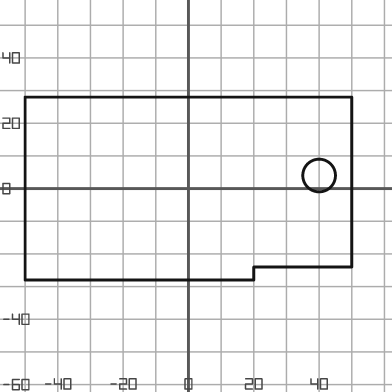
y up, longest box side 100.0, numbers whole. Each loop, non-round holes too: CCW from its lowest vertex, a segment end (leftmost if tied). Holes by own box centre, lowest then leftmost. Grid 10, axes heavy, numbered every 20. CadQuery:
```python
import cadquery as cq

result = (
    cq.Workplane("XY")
    .moveTo(-50.0, -28.0)
    .lineTo(20.0, -28.0)
    .lineTo(20.0, -24.0)
    .lineTo(50.0, -24.0)
    .lineTo(50.0, 28.0)
    .lineTo(-50.0, 28.0)
    .close()
    .moveTo(40.0, 4.0)
    .circle(5.0)
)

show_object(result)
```